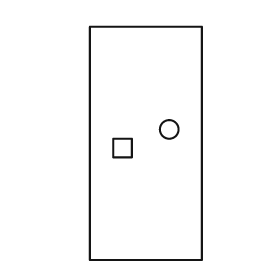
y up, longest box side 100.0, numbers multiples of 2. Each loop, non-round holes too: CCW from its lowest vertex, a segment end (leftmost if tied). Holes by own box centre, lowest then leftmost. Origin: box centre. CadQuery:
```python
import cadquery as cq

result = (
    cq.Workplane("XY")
    .moveTo(-24.0, -50.0)
    .lineTo(24.0, -50.0)
    .lineTo(24.0, 50.0)
    .lineTo(-24.0, 50.0)
    .close()
    .moveTo(-14.0, -6.0)
    .lineTo(-6.0, -6.0)
    .lineTo(-6.0, 2.0)
    .lineTo(-14.0, 2.0)
    .close()
    .moveTo(10.0, 6.0)
    .circle(4.0)
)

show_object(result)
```